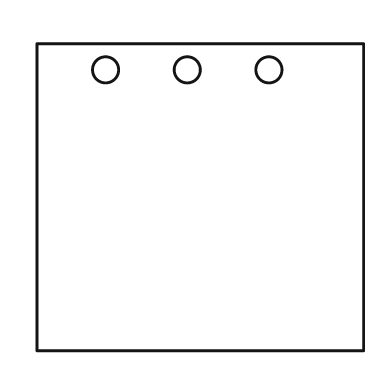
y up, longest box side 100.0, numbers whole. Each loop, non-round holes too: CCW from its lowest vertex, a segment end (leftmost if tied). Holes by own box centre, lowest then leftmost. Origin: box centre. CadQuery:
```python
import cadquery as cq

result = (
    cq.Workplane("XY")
    .moveTo(-50.0, -47.0)
    .lineTo(50.0, -47.0)
    .lineTo(50.0, 47.0)
    .lineTo(-50.0, 47.0)
    .close()
    .moveTo(-29.0, 39.0)
    .circle(4.0)
    .moveTo(-4.0, 39.0)
    .circle(4.0)
    .moveTo(21.0, 39.0)
    .circle(4.0)
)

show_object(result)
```